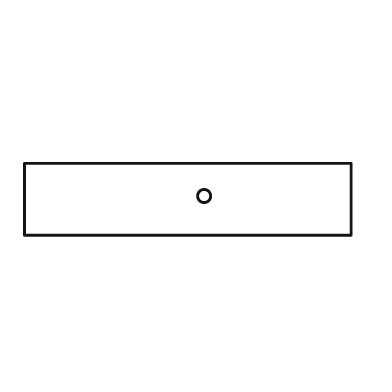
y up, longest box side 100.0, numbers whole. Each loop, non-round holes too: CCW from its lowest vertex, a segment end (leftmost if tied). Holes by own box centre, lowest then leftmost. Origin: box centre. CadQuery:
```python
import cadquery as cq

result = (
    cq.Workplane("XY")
    .moveTo(-50.0, -11.0)
    .lineTo(50.0, -11.0)
    .lineTo(50.0, 11.0)
    .lineTo(-50.0, 11.0)
    .close()
    .moveTo(5.0, 1.0)
    .circle(2.0)
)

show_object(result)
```